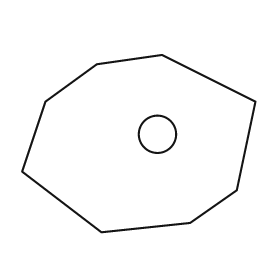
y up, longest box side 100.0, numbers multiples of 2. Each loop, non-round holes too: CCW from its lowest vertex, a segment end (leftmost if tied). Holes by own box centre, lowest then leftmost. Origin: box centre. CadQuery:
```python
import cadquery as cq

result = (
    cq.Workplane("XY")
    .moveTo(-16.0, -38.0)
    .lineTo(22.0, -34.0)
    .lineTo(42.0, -20.0)
    .lineTo(50.0, 18.0)
    .lineTo(10.0, 38.0)
    .lineTo(-18.0, 34.0)
    .lineTo(-40.0, 18.0)
    .lineTo(-50.0, -12.0)
    .close()
    .moveTo(8.0, 4.0)
    .circle(8.0)
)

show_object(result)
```